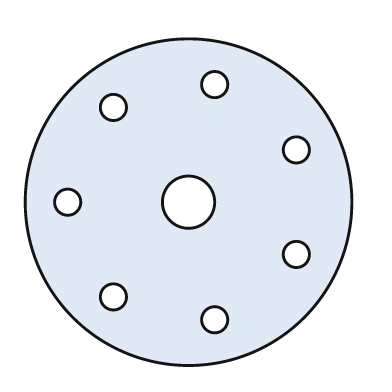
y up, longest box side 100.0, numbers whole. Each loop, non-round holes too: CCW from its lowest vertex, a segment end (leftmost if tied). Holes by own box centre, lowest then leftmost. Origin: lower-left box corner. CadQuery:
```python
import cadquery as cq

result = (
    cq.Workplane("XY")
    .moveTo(50.0, 50.0)
    .circle(50.0)
    .moveTo(58.0, 14.0)
    .circle(4.0)
    .moveTo(27.0, 21.0)
    .circle(4.0)
    .moveTo(83.0, 34.0)
    .circle(4.0)
    .moveTo(13.0, 50.0)
    .circle(4.0)
    .moveTo(50.0, 50.0)
    .circle(8.0)
    .moveTo(83.0, 66.0)
    .circle(4.0)
    .moveTo(27.0, 79.0)
    .circle(4.0)
    .moveTo(58.0, 86.0)
    .circle(4.0)
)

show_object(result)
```